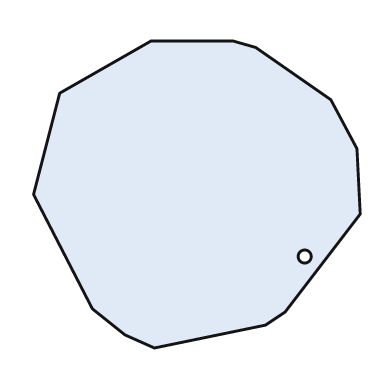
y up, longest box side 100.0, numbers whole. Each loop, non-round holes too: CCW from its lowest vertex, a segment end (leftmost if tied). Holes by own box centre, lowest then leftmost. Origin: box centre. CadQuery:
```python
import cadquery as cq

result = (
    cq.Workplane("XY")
    .moveTo(-13.0, -47.0)
    .lineTo(21.0, -40.0)
    .lineTo(27.0, -36.0)
    .lineTo(50.0, -6.0)
    .lineTo(49.0, 14.0)
    .lineTo(41.0, 29.0)
    .lineTo(18.0, 45.0)
    .lineTo(11.0, 47.0)
    .lineTo(-14.0, 47.0)
    .lineTo(-42.0, 31.0)
    .lineTo(-50.0, 0.0)
    .lineTo(-32.0, -35.0)
    .lineTo(-22.0, -43.0)
    .close()
    .moveTo(33.0, -19.0)
    .circle(2.0)
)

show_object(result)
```